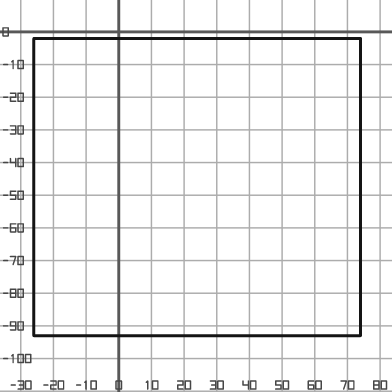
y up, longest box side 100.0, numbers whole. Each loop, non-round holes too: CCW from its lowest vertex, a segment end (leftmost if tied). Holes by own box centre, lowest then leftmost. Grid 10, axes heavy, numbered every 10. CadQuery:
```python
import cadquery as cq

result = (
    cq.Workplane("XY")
    .moveTo(-26.0, -93.0)
    .lineTo(74.0, -93.0)
    .lineTo(74.0, -2.0)
    .lineTo(-26.0, -2.0)
    .close()
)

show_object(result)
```